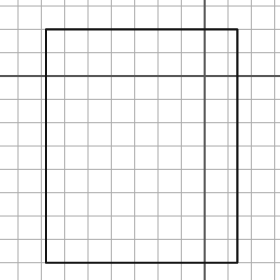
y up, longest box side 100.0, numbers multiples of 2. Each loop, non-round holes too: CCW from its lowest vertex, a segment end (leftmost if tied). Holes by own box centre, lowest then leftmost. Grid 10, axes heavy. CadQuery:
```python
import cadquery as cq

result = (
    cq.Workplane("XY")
    .moveTo(-68.0, -80.0)
    .lineTo(14.0, -80.0)
    .lineTo(14.0, 20.0)
    .lineTo(-68.0, 20.0)
    .close()
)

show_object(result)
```